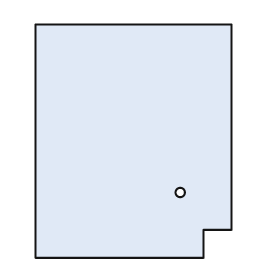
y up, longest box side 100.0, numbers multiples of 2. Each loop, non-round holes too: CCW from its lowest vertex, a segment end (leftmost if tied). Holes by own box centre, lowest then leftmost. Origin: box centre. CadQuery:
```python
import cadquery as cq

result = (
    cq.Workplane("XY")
    .moveTo(-42.0, -50.0)
    .lineTo(30.0, -50.0)
    .lineTo(30.0, -38.0)
    .lineTo(42.0, -38.0)
    .lineTo(42.0, 50.0)
    .lineTo(-42.0, 50.0)
    .close()
    .moveTo(20.0, -22.0)
    .circle(2.0)
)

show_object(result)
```